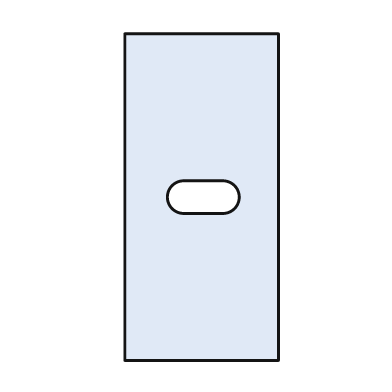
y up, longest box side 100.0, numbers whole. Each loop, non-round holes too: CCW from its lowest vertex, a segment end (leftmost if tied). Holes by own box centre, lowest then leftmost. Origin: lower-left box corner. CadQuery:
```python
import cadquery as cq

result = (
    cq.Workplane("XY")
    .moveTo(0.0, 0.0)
    .lineTo(47.0, 0.0)
    .lineTo(47.0, 100.0)
    .lineTo(0.0, 100.0)
    .close()
    .moveTo(18.0, 45.0)
    .lineTo(30.0, 45.0)
    .threePointArc((35.0, 50.0), (30.0, 55.0))
    .lineTo(18.0, 55.0)
    .threePointArc((13.0, 50.0), (18.0, 45.0))
    .close()
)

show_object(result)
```